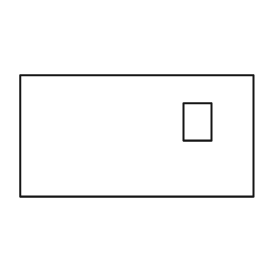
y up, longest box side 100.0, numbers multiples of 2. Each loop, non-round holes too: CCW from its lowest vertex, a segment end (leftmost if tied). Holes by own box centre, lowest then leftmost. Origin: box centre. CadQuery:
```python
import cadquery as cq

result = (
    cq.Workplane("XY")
    .moveTo(-50.0, -26.0)
    .lineTo(50.0, -26.0)
    .lineTo(50.0, 26.0)
    .lineTo(-50.0, 26.0)
    .close()
    .moveTo(20.0, -2.0)
    .lineTo(32.0, -2.0)
    .lineTo(32.0, 14.0)
    .lineTo(20.0, 14.0)
    .close()
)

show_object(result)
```